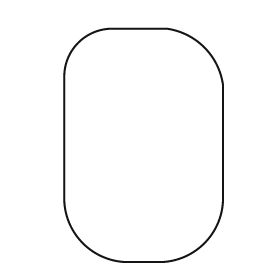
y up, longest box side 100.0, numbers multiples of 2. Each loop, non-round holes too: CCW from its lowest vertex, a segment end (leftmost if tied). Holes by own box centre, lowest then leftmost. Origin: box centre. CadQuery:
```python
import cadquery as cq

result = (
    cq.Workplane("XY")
    .moveTo(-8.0, -50.0)
    .lineTo(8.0, -50.0)
    .threePointArc((26.0, -42.0), (34.0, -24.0))
    .lineTo(34.0, 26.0)
    .threePointArc((26.0, 42.0), (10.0, 50.0))
    .lineTo(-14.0, 50.0)
    .threePointArc((-28.0, 44.0), (-34.0, 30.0))
    .lineTo(-34.0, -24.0)
    .threePointArc((-26.0, -42.0), (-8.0, -50.0))
    .close()
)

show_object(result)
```